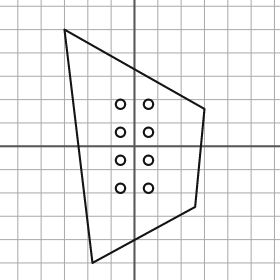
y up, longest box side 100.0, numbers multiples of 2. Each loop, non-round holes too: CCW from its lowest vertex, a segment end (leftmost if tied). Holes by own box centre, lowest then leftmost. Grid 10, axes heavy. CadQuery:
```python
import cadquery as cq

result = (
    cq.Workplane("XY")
    .moveTo(-18.0, -50.0)
    .lineTo(26.0, -26.0)
    .lineTo(30.0, 16.0)
    .lineTo(-30.0, 50.0)
    .close()
    .moveTo(-6.0, -18.0)
    .circle(2.0)
    .moveTo(6.0, -18.0)
    .circle(2.0)
    .moveTo(-6.0, -6.0)
    .circle(2.0)
    .moveTo(6.0, -6.0)
    .circle(2.0)
    .moveTo(-6.0, 6.0)
    .circle(2.0)
    .moveTo(6.0, 6.0)
    .circle(2.0)
    .moveTo(-6.0, 18.0)
    .circle(2.0)
    .moveTo(6.0, 18.0)
    .circle(2.0)
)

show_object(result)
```